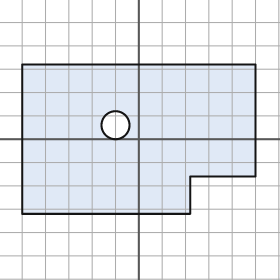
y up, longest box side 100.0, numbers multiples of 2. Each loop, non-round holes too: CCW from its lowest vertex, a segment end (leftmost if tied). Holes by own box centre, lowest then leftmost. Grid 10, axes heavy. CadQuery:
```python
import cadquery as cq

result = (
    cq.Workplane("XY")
    .moveTo(-50.0, -32.0)
    .lineTo(22.0, -32.0)
    .lineTo(22.0, -16.0)
    .lineTo(50.0, -16.0)
    .lineTo(50.0, 32.0)
    .lineTo(-50.0, 32.0)
    .close()
    .moveTo(-10.0, 6.0)
    .circle(6.0)
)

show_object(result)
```